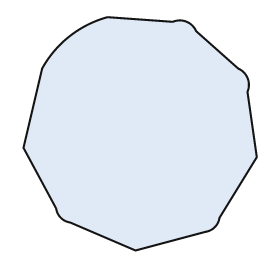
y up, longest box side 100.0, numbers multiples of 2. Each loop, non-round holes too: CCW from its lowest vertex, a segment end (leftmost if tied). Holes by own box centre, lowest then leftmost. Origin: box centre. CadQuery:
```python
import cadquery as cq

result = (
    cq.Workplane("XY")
    .moveTo(-2.0, -50.0)
    .lineTo(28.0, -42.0)
    .threePointArc((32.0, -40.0), (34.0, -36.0))
    .lineTo(50.0, -10.0)
    .lineTo(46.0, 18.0)
    .threePointArc((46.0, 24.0), (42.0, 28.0))
    .lineTo(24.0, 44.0)
    .threePointArc((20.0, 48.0), (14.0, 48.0))
    .lineTo(-14.0, 50.0)
    .threePointArc((-30.0, 42.0), (-42.0, 28.0))
    .lineTo(-50.0, -6.0)
    .lineTo(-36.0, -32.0)
    .threePointArc((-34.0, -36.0), (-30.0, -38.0))
    .close()
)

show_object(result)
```